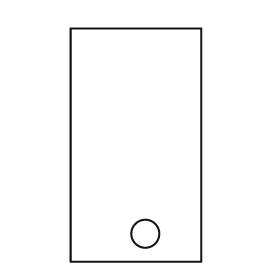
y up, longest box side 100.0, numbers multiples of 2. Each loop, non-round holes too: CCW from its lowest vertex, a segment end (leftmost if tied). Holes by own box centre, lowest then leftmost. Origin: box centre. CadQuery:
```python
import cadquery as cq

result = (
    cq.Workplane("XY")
    .moveTo(-28.0, -50.0)
    .lineTo(28.0, -50.0)
    .lineTo(28.0, 50.0)
    .lineTo(-28.0, 50.0)
    .close()
    .moveTo(4.0, -38.0)
    .circle(6.0)
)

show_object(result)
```